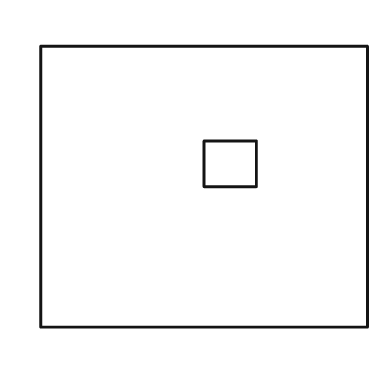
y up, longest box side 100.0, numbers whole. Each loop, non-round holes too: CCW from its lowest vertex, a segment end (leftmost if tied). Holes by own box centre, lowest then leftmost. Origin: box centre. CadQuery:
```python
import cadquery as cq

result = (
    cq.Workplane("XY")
    .moveTo(-50.0, -43.0)
    .lineTo(50.0, -43.0)
    .lineTo(50.0, 43.0)
    .lineTo(-50.0, 43.0)
    .close()
    .moveTo(0.0, 0.0)
    .lineTo(16.0, 0.0)
    .lineTo(16.0, 14.0)
    .lineTo(0.0, 14.0)
    .close()
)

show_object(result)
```